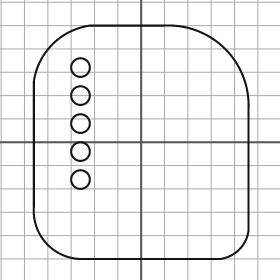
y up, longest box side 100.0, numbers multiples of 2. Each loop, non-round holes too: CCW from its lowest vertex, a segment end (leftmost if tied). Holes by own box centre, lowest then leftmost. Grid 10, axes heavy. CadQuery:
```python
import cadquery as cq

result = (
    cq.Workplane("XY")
    .moveTo(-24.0, -50.0)
    .lineTo(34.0, -50.0)
    .threePointArc((42.0, -46.0), (46.0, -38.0))
    .lineTo(46.0, 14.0)
    .threePointArc((36.0, 40.0), (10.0, 50.0))
    .lineTo(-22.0, 50.0)
    .threePointArc((-38.0, 42.0), (-46.0, 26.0))
    .lineTo(-46.0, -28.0)
    .threePointArc((-40.0, -44.0), (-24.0, -50.0))
    .close()
    .moveTo(-26.0, -16.0)
    .circle(4.0)
    .moveTo(-26.0, -4.0)
    .circle(4.0)
    .moveTo(-26.0, 8.0)
    .circle(4.0)
    .moveTo(-26.0, 20.0)
    .circle(4.0)
    .moveTo(-26.0, 32.0)
    .circle(4.0)
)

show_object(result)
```